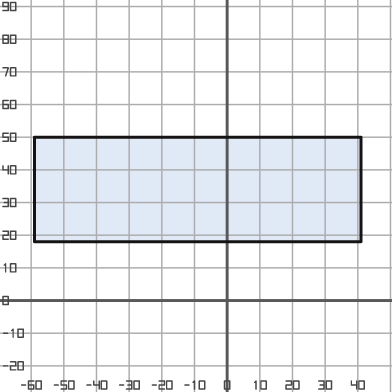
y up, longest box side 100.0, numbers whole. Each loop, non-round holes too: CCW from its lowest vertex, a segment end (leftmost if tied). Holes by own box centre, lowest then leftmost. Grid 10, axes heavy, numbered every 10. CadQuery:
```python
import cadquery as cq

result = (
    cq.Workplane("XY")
    .moveTo(-59.0, 18.0)
    .lineTo(41.0, 18.0)
    .lineTo(41.0, 50.0)
    .lineTo(-59.0, 50.0)
    .close()
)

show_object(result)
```